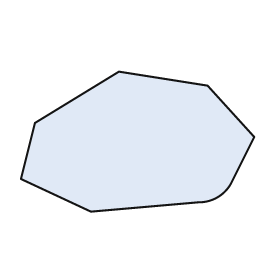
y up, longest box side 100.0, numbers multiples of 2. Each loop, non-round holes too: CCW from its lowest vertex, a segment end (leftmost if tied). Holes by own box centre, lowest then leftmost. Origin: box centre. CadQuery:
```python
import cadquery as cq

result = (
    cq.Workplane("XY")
    .moveTo(-20.0, -30.0)
    .lineTo(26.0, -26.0)
    .threePointArc((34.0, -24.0), (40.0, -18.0))
    .lineTo(50.0, 2.0)
    .lineTo(30.0, 24.0)
    .lineTo(-8.0, 30.0)
    .lineTo(-44.0, 8.0)
    .lineTo(-50.0, -16.0)
    .close()
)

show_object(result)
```